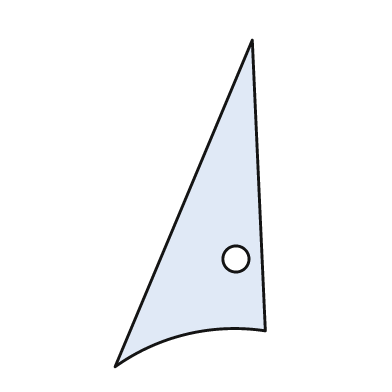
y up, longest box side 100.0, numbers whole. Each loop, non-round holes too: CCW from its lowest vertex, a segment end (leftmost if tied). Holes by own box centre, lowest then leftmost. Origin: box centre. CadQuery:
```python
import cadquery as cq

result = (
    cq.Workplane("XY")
    .moveTo(-23.0, -50.0)
    .threePointArc((-1.0, -40.0), (23.0, -39.0))
    .lineTo(19.0, 50.0)
    .close()
    .moveTo(14.0, -17.0)
    .circle(4.0)
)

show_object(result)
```